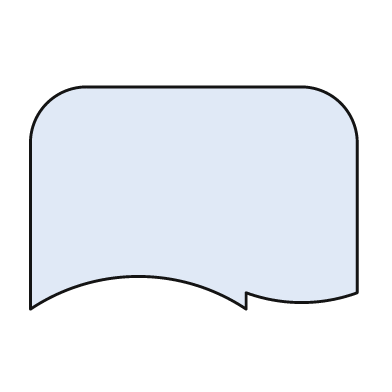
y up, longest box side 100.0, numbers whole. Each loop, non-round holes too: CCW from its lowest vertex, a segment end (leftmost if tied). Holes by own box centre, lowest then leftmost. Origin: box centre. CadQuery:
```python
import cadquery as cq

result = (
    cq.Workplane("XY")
    .moveTo(-50.0, -34.0)
    .threePointArc((-17.0, -24.0), (16.0, -34.0))
    .lineTo(16.0, -29.0)
    .threePointArc((33.0, -32.0), (50.0, -29.0))
    .lineTo(50.0, 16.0)
    .threePointArc((45.0, 29.0), (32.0, 34.0))
    .lineTo(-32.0, 34.0)
    .threePointArc((-45.0, 29.0), (-50.0, 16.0))
    .close()
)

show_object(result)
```